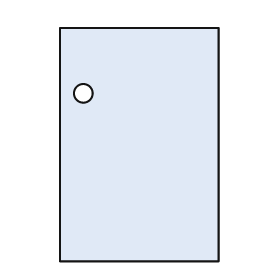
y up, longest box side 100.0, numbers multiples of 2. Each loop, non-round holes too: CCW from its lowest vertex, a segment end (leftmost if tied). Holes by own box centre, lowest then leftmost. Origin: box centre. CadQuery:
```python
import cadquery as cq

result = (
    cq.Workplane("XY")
    .moveTo(-34.0, -50.0)
    .lineTo(34.0, -50.0)
    .lineTo(34.0, 50.0)
    .lineTo(-34.0, 50.0)
    .close()
    .moveTo(-24.0, 22.0)
    .circle(4.0)
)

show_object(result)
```